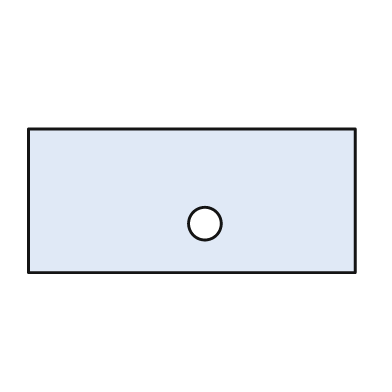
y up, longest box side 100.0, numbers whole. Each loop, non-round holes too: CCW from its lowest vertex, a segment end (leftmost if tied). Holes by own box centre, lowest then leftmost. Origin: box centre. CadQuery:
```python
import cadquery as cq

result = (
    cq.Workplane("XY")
    .moveTo(-50.0, -22.0)
    .lineTo(50.0, -22.0)
    .lineTo(50.0, 22.0)
    .lineTo(-50.0, 22.0)
    .close()
    .moveTo(4.0, -7.0)
    .circle(5.0)
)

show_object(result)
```